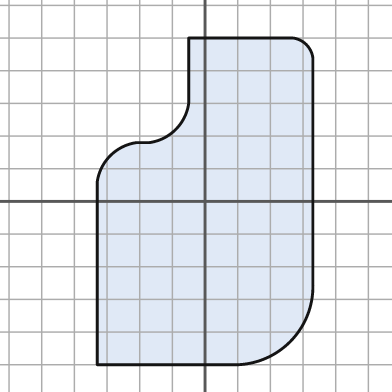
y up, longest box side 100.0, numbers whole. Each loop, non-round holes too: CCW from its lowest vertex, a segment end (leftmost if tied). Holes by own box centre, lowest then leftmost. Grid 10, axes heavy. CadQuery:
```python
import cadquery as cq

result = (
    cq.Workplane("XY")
    .moveTo(-33.0, -50.0)
    .lineTo(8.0, -50.0)
    .threePointArc((26.0, -43.0), (33.0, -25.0))
    .lineTo(33.0, 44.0)
    .threePointArc((31.0, 48.0), (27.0, 50.0))
    .lineTo(-5.0, 50.0)
    .lineTo(-5.0, 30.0)
    .threePointArc((-9.0, 22.0), (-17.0, 18.0))
    .lineTo(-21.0, 18.0)
    .threePointArc((-29.0, 14.0), (-33.0, 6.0))
    .close()
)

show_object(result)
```